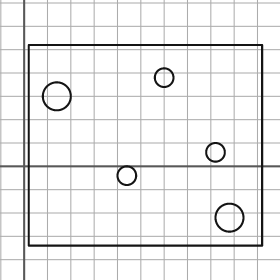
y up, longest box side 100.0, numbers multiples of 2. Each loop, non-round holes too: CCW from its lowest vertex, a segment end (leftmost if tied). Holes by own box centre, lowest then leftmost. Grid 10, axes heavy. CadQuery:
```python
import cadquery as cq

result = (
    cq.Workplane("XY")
    .moveTo(2.0, -34.0)
    .lineTo(102.0, -34.0)
    .lineTo(102.0, 52.0)
    .lineTo(2.0, 52.0)
    .close()
    .moveTo(88.0, -22.0)
    .circle(6.0)
    .moveTo(44.0, -4.0)
    .circle(4.0)
    .moveTo(82.0, 6.0)
    .circle(4.0)
    .moveTo(14.0, 30.0)
    .circle(6.0)
    .moveTo(60.0, 38.0)
    .circle(4.0)
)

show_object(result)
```